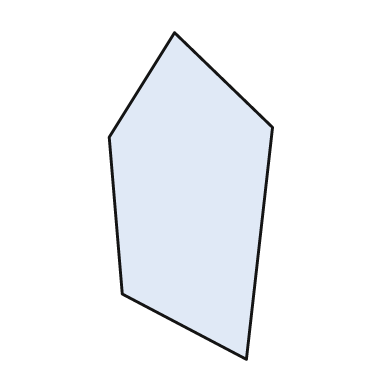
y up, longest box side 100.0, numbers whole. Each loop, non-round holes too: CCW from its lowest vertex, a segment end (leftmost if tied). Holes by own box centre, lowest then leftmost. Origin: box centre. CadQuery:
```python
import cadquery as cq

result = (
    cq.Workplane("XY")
    .moveTo(17.0, -50.0)
    .lineTo(25.0, 21.0)
    .lineTo(-5.0, 50.0)
    .lineTo(-25.0, 18.0)
    .lineTo(-21.0, -30.0)
    .close()
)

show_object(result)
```